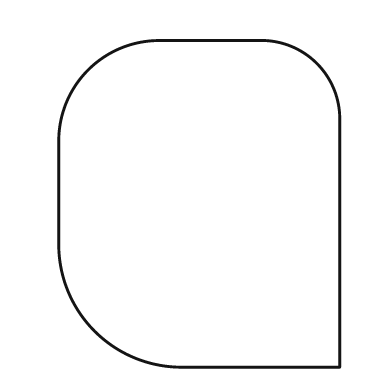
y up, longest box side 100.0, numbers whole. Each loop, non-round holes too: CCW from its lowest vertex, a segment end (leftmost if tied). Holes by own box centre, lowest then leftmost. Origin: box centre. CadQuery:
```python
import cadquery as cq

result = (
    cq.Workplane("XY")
    .moveTo(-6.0, -50.0)
    .lineTo(43.0, -50.0)
    .lineTo(43.0, 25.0)
    .threePointArc((36.0, 43.0), (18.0, 50.0))
    .lineTo(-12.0, 50.0)
    .threePointArc((-34.0, 41.0), (-43.0, 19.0))
    .lineTo(-43.0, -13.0)
    .threePointArc((-32.0, -39.0), (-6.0, -50.0))
    .close()
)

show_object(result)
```